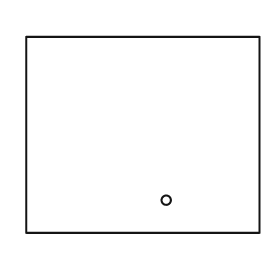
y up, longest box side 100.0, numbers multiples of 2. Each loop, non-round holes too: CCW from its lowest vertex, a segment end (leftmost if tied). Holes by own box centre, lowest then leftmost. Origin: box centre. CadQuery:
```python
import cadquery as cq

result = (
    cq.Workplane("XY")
    .moveTo(-50.0, -42.0)
    .lineTo(50.0, -42.0)
    .lineTo(50.0, 42.0)
    .lineTo(-50.0, 42.0)
    .close()
    .moveTo(10.0, -28.0)
    .circle(2.0)
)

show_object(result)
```